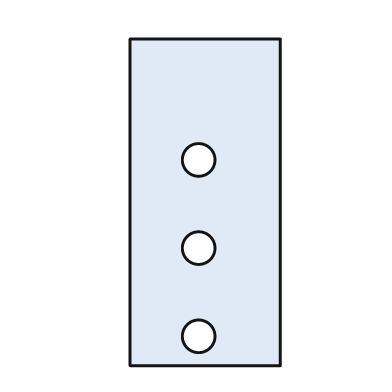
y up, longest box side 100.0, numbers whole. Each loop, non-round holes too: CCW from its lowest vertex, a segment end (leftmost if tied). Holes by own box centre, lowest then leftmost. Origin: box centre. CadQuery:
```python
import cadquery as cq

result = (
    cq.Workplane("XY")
    .moveTo(-23.0, -50.0)
    .lineTo(23.0, -50.0)
    .lineTo(23.0, 50.0)
    .lineTo(-23.0, 50.0)
    .close()
    .moveTo(-2.0, -41.0)
    .circle(5.0)
    .moveTo(-2.0, -14.0)
    .circle(5.0)
    .moveTo(-2.0, 13.0)
    .circle(5.0)
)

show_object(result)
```